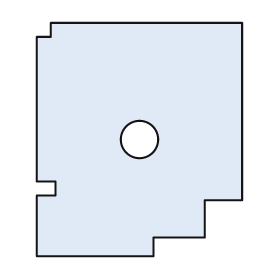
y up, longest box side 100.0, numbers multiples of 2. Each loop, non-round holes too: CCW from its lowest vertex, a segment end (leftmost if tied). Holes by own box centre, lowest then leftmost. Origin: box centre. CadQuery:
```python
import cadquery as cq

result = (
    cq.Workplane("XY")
    .moveTo(-44.0, -50.0)
    .lineTo(6.0, -50.0)
    .lineTo(6.0, -42.0)
    .lineTo(28.0, -42.0)
    .lineTo(28.0, -26.0)
    .lineTo(44.0, -26.0)
    .lineTo(44.0, 50.0)
    .lineTo(-38.0, 50.0)
    .lineTo(-38.0, 44.0)
    .lineTo(-44.0, 44.0)
    .lineTo(-44.0, -18.0)
    .lineTo(-36.0, -18.0)
    .lineTo(-36.0, -24.0)
    .lineTo(-44.0, -24.0)
    .close()
    .moveTo(0.0, 0.0)
    .circle(8.0)
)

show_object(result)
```